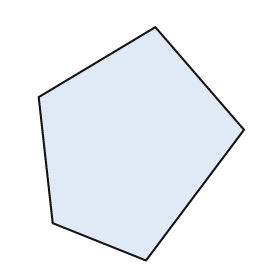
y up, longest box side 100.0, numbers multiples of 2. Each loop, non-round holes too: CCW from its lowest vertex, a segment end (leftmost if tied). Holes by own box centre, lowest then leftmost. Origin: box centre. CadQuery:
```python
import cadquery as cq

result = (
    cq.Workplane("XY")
    .moveTo(2.0, -50.0)
    .lineTo(44.0, 6.0)
    .lineTo(6.0, 50.0)
    .lineTo(-44.0, 20.0)
    .lineTo(-38.0, -34.0)
    .close()
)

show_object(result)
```